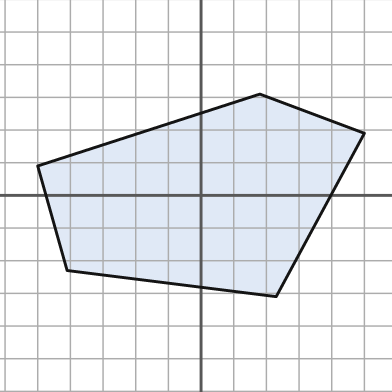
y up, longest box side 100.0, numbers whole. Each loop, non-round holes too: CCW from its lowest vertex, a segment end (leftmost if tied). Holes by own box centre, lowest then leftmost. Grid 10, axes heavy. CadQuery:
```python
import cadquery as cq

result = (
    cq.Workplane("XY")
    .moveTo(23.0, -31.0)
    .lineTo(50.0, 19.0)
    .lineTo(18.0, 31.0)
    .lineTo(-50.0, 9.0)
    .lineTo(-41.0, -23.0)
    .close()
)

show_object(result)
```